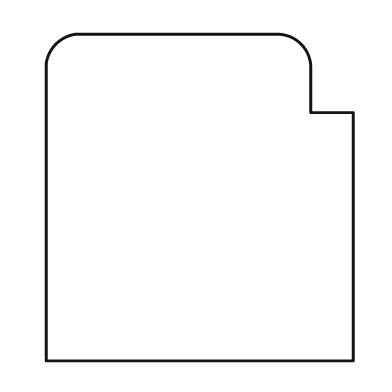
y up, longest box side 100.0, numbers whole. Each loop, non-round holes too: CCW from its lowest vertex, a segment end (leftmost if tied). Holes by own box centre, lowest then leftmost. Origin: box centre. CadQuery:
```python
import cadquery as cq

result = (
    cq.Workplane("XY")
    .moveTo(-47.0, -50.0)
    .lineTo(47.0, -50.0)
    .lineTo(47.0, 26.0)
    .lineTo(34.0, 26.0)
    .lineTo(34.0, 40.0)
    .threePointArc((31.0, 47.0), (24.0, 50.0))
    .lineTo(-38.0, 50.0)
    .threePointArc((-44.0, 47.0), (-47.0, 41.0))
    .close()
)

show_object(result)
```